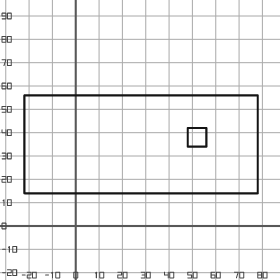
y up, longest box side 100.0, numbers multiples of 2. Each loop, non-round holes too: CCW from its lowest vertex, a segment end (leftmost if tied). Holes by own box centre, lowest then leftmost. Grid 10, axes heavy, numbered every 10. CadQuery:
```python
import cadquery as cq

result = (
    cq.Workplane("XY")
    .moveTo(-22.0, 14.0)
    .lineTo(78.0, 14.0)
    .lineTo(78.0, 56.0)
    .lineTo(-22.0, 56.0)
    .close()
    .moveTo(48.0, 34.0)
    .lineTo(56.0, 34.0)
    .lineTo(56.0, 42.0)
    .lineTo(48.0, 42.0)
    .close()
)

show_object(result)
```